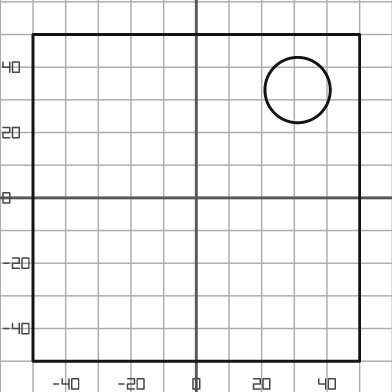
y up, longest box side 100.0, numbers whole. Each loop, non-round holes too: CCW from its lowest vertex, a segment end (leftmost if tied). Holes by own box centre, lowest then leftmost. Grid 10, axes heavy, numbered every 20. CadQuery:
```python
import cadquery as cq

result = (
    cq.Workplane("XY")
    .moveTo(-50.0, -50.0)
    .lineTo(50.0, -50.0)
    .lineTo(50.0, 50.0)
    .lineTo(-50.0, 50.0)
    .close()
    .moveTo(31.0, 33.0)
    .circle(10.0)
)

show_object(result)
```